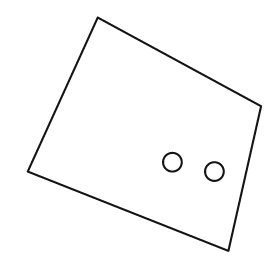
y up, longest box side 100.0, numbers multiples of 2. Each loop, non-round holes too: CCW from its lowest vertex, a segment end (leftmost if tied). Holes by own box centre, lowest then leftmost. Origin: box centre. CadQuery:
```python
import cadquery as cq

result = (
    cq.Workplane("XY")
    .moveTo(36.0, -50.0)
    .lineTo(50.0, 12.0)
    .lineTo(-20.0, 50.0)
    .lineTo(-50.0, -16.0)
    .close()
    .moveTo(30.0, -16.0)
    .circle(4.0)
    .moveTo(12.0, -12.0)
    .circle(4.0)
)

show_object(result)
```